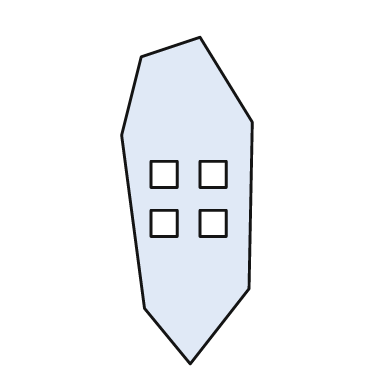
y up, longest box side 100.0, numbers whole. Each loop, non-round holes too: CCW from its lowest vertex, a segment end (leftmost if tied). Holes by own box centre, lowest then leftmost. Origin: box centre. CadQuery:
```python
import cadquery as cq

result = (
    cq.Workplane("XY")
    .moveTo(1.0, -50.0)
    .lineTo(19.0, -27.0)
    .lineTo(20.0, 24.0)
    .lineTo(4.0, 50.0)
    .lineTo(-14.0, 44.0)
    .lineTo(-20.0, 20.0)
    .lineTo(-13.0, -33.0)
    .close()
    .moveTo(-11.0, -11.0)
    .lineTo(-3.0, -11.0)
    .lineTo(-3.0, -3.0)
    .lineTo(-11.0, -3.0)
    .close()
    .moveTo(4.0, -11.0)
    .lineTo(12.0, -11.0)
    .lineTo(12.0, -3.0)
    .lineTo(4.0, -3.0)
    .close()
    .moveTo(-11.0, 4.0)
    .lineTo(-3.0, 4.0)
    .lineTo(-3.0, 12.0)
    .lineTo(-11.0, 12.0)
    .close()
    .moveTo(4.0, 4.0)
    .lineTo(12.0, 4.0)
    .lineTo(12.0, 12.0)
    .lineTo(4.0, 12.0)
    .close()
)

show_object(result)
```